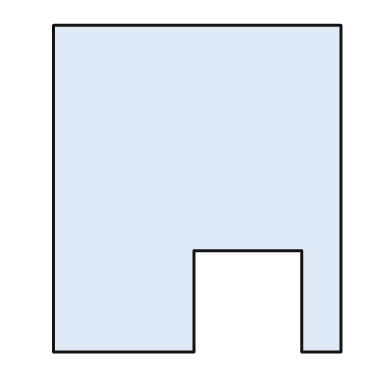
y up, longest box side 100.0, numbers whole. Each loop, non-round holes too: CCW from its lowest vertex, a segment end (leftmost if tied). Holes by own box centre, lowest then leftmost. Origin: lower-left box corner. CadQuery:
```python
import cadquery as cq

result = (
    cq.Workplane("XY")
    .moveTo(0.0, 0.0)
    .lineTo(43.0, 0.0)
    .lineTo(43.0, 31.0)
    .lineTo(76.0, 31.0)
    .lineTo(76.0, 0.0)
    .lineTo(88.0, 0.0)
    .lineTo(88.0, 100.0)
    .lineTo(0.0, 100.0)
    .close()
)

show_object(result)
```